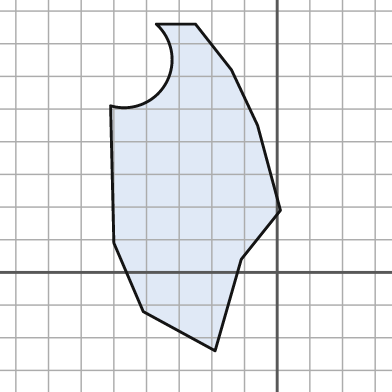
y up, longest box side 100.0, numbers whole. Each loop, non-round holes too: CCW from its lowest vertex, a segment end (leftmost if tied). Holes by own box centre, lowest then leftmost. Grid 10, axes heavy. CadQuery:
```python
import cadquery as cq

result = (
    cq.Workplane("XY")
    .moveTo(-19.0, -24.0)
    .lineTo(-11.0, 4.0)
    .lineTo(1.0, 19.0)
    .lineTo(-6.0, 45.0)
    .lineTo(-14.0, 62.0)
    .lineTo(-25.0, 76.0)
    .lineTo(-37.0, 76.0)
    .threePointArc((-34.0, 58.0), (-51.0, 51.0))
    .lineTo(-50.0, 9.0)
    .lineTo(-41.0, -12.0)
    .close()
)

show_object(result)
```